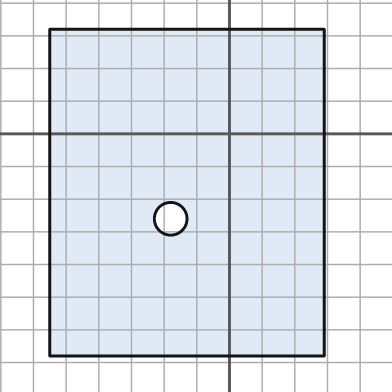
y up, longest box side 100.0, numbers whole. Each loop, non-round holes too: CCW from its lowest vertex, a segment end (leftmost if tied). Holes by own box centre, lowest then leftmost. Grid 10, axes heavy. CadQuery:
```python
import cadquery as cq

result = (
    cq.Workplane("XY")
    .moveTo(-55.0, -68.0)
    .lineTo(29.0, -68.0)
    .lineTo(29.0, 32.0)
    .lineTo(-55.0, 32.0)
    .close()
    .moveTo(-18.0, -26.0)
    .circle(5.0)
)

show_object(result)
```